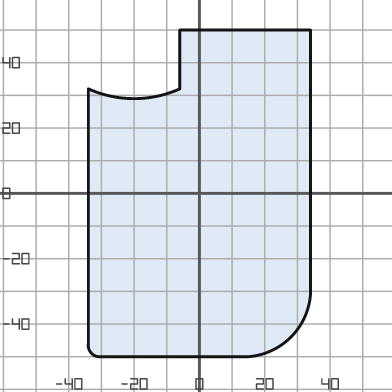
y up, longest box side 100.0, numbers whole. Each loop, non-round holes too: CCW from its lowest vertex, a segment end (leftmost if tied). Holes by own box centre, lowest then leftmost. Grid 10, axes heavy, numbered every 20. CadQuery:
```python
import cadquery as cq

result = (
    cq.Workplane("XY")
    .moveTo(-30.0, -50.0)
    .lineTo(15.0, -50.0)
    .threePointArc((28.0, -44.0), (34.0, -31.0))
    .lineTo(34.0, 50.0)
    .lineTo(-6.0, 50.0)
    .lineTo(-6.0, 32.0)
    .threePointArc((-20.0, 29.0), (-34.0, 32.0))
    .lineTo(-34.0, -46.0)
    .threePointArc((-33.0, -49.0), (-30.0, -50.0))
    .close()
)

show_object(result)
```